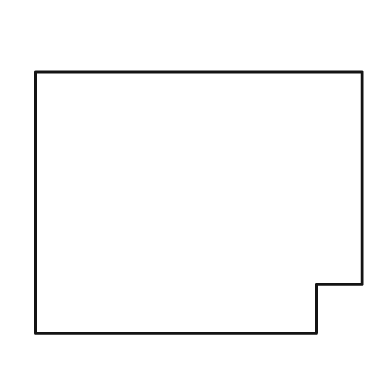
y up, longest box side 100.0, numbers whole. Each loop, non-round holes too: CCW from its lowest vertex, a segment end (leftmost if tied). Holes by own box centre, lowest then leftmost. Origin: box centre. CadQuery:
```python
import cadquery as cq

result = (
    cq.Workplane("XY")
    .moveTo(-50.0, -40.0)
    .lineTo(36.0, -40.0)
    .lineTo(36.0, -25.0)
    .lineTo(50.0, -25.0)
    .lineTo(50.0, 40.0)
    .lineTo(-50.0, 40.0)
    .close()
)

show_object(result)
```